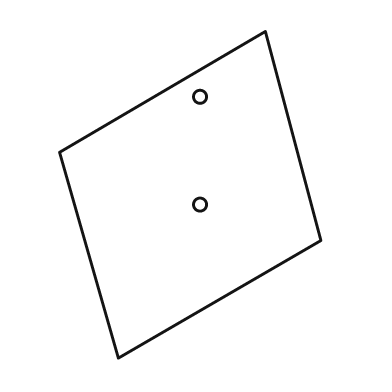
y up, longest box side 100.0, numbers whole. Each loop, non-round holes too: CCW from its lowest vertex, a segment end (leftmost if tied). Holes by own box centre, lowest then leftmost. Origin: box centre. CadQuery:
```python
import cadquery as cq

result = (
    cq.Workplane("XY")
    .moveTo(-22.0, -50.0)
    .lineTo(40.0, -14.0)
    .lineTo(23.0, 50.0)
    .lineTo(-40.0, 13.0)
    .close()
    .moveTo(3.0, -3.0)
    .circle(2.0)
    .moveTo(3.0, 30.0)
    .circle(2.0)
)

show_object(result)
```